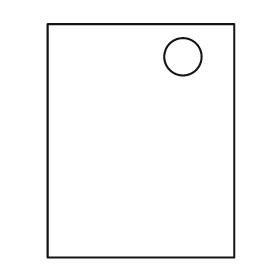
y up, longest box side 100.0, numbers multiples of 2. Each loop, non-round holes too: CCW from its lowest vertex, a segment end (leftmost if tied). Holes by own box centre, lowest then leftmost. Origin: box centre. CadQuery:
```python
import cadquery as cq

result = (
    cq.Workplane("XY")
    .moveTo(-40.0, -50.0)
    .lineTo(40.0, -50.0)
    .lineTo(40.0, 50.0)
    .lineTo(-40.0, 50.0)
    .close()
    .moveTo(18.0, 36.0)
    .circle(8.0)
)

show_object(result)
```